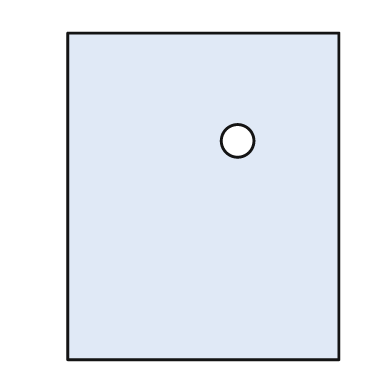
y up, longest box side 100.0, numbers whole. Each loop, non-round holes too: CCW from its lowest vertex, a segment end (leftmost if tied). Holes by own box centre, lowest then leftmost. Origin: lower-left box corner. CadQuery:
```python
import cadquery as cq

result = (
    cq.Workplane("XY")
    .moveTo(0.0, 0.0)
    .lineTo(83.0, 0.0)
    .lineTo(83.0, 100.0)
    .lineTo(0.0, 100.0)
    .close()
    .moveTo(52.0, 67.0)
    .circle(5.0)
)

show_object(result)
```